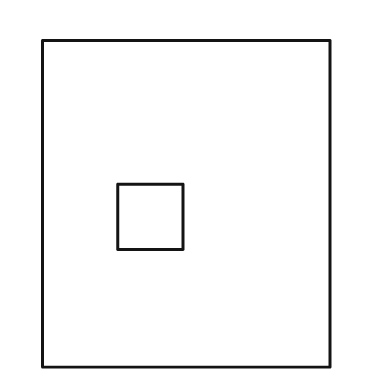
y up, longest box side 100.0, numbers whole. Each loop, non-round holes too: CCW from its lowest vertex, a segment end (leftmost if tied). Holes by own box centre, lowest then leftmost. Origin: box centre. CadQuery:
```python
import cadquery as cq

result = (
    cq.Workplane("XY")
    .moveTo(-44.0, -50.0)
    .lineTo(44.0, -50.0)
    .lineTo(44.0, 50.0)
    .lineTo(-44.0, 50.0)
    .close()
    .moveTo(-21.0, -14.0)
    .lineTo(-1.0, -14.0)
    .lineTo(-1.0, 6.0)
    .lineTo(-21.0, 6.0)
    .close()
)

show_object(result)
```